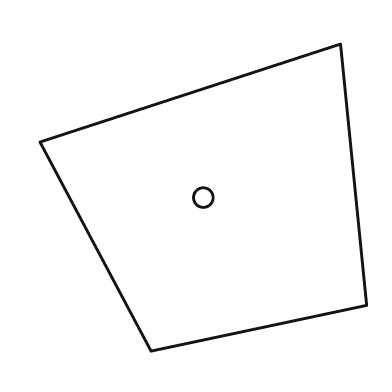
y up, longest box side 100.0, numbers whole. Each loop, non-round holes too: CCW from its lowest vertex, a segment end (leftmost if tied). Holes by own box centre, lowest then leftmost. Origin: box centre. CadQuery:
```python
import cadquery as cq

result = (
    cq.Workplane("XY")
    .moveTo(-16.0, -47.0)
    .lineTo(50.0, -33.0)
    .lineTo(42.0, 47.0)
    .lineTo(-50.0, 17.0)
    .close()
    .moveTo(0.0, 0.0)
    .circle(3.0)
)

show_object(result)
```